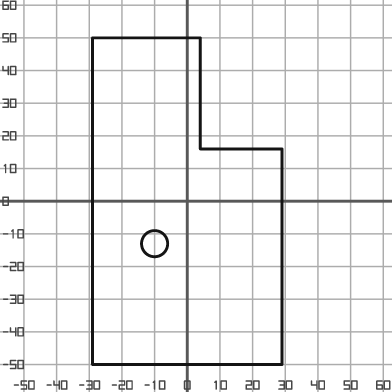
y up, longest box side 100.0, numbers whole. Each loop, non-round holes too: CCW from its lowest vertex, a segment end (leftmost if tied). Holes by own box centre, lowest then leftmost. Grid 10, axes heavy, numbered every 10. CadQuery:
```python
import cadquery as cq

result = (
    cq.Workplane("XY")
    .moveTo(-29.0, -50.0)
    .lineTo(29.0, -50.0)
    .lineTo(29.0, 16.0)
    .lineTo(4.0, 16.0)
    .lineTo(4.0, 50.0)
    .lineTo(-29.0, 50.0)
    .close()
    .moveTo(-10.0, -13.0)
    .circle(4.0)
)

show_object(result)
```